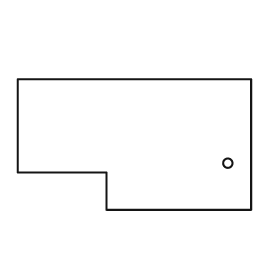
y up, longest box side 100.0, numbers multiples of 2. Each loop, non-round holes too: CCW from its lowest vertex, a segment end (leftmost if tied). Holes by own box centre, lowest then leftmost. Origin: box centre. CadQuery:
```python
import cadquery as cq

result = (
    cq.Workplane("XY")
    .moveTo(-12.0, -28.0)
    .lineTo(50.0, -28.0)
    .lineTo(50.0, 28.0)
    .lineTo(-50.0, 28.0)
    .lineTo(-50.0, -12.0)
    .lineTo(-12.0, -12.0)
    .close()
    .moveTo(40.0, -8.0)
    .circle(2.0)
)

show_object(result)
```